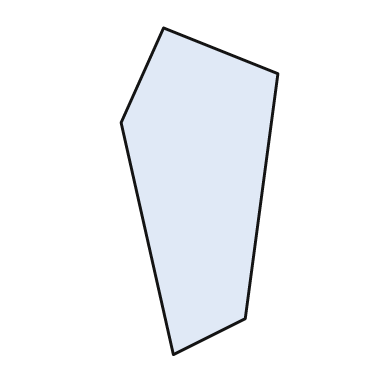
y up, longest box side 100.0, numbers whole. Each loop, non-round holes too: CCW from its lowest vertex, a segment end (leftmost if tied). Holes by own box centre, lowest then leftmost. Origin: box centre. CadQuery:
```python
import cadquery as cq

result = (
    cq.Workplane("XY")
    .moveTo(-8.0, -50.0)
    .lineTo(14.0, -39.0)
    .lineTo(24.0, 36.0)
    .lineTo(-11.0, 50.0)
    .lineTo(-24.0, 21.0)
    .close()
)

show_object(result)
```